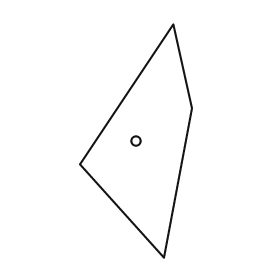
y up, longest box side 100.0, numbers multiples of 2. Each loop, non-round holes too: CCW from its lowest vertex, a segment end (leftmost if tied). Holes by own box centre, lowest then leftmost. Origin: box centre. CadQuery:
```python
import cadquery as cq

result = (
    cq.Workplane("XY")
    .moveTo(12.0, -50.0)
    .lineTo(24.0, 14.0)
    .lineTo(16.0, 50.0)
    .lineTo(-24.0, -10.0)
    .close()
    .moveTo(0.0, 0.0)
    .circle(2.0)
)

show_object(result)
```